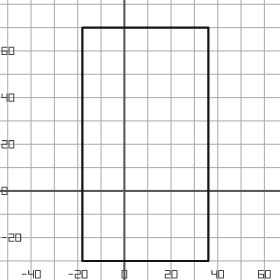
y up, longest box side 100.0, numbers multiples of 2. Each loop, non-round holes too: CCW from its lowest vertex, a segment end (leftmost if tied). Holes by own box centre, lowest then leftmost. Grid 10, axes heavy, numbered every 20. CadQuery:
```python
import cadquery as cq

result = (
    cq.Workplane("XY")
    .moveTo(-18.0, -30.0)
    .lineTo(36.0, -30.0)
    .lineTo(36.0, 70.0)
    .lineTo(-18.0, 70.0)
    .close()
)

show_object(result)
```